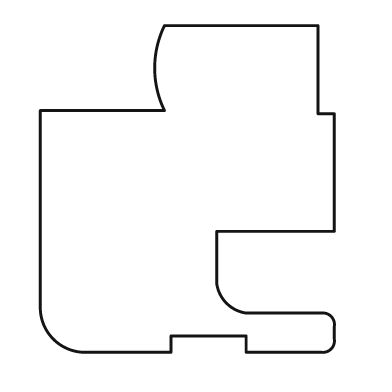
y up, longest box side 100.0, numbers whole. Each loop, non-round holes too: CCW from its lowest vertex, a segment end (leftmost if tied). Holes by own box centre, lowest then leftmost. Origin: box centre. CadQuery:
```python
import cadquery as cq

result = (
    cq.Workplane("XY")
    .moveTo(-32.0, -50.0)
    .lineTo(-5.0, -50.0)
    .lineTo(-5.0, -45.0)
    .lineTo(18.0, -45.0)
    .lineTo(18.0, -50.0)
    .lineTo(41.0, -50.0)
    .threePointArc((44.0, -49.0), (45.0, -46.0))
    .lineTo(45.0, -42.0)
    .threePointArc((44.0, -39.0), (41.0, -38.0))
    .lineTo(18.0, -38.0)
    .threePointArc((12.0, -35.0), (9.0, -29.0))
    .lineTo(9.0, -13.0)
    .lineTo(45.0, -13.0)
    .lineTo(45.0, 23.0)
    .lineTo(40.0, 23.0)
    .lineTo(40.0, 50.0)
    .lineTo(-7.0, 50.0)
    .threePointArc((-10.0, 37.0), (-7.0, 24.0))
    .lineTo(-45.0, 24.0)
    .lineTo(-45.0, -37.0)
    .threePointArc((-41.0, -46.0), (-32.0, -50.0))
    .close()
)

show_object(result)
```